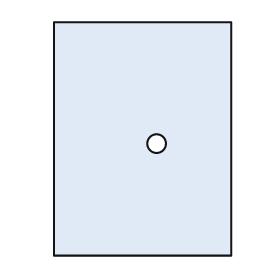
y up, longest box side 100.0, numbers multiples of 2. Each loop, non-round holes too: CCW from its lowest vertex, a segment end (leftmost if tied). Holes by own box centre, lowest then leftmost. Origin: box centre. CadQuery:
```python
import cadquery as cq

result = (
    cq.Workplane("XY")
    .moveTo(-38.0, -50.0)
    .lineTo(38.0, -50.0)
    .lineTo(38.0, 50.0)
    .lineTo(-38.0, 50.0)
    .close()
    .moveTo(6.0, -2.0)
    .circle(4.0)
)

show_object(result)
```